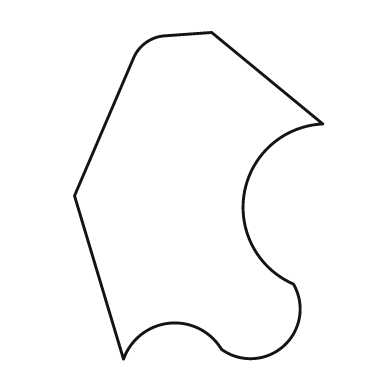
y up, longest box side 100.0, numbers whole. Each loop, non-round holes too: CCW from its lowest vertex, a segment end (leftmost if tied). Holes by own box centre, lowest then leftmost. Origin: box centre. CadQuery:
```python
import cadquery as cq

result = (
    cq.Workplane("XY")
    .moveTo(-23.0, -50.0)
    .threePointArc((-9.0, -39.0), (7.0, -47.0))
    .threePointArc((26.0, -46.0), (29.0, -27.0))
    .threePointArc((14.0, 1.0), (38.0, 22.0))
    .lineTo(4.0, 50.0)
    .lineTo(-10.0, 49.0)
    .threePointArc((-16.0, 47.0), (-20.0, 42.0))
    .lineTo(-38.0, 0.0)
    .close()
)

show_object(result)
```